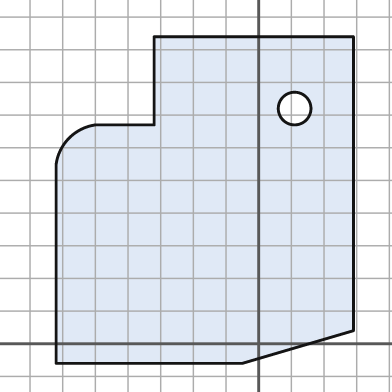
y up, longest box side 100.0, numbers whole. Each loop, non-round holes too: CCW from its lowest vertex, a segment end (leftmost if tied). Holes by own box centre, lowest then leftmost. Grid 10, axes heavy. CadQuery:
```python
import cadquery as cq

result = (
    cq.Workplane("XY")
    .moveTo(-62.0, -6.0)
    .lineTo(-5.0, -6.0)
    .lineTo(29.0, 4.0)
    .lineTo(29.0, 94.0)
    .lineTo(-32.0, 94.0)
    .lineTo(-32.0, 67.0)
    .lineTo(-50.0, 67.0)
    .threePointArc((-58.0, 63.0), (-62.0, 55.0))
    .close()
    .moveTo(11.0, 72.0)
    .circle(5.0)
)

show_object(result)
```